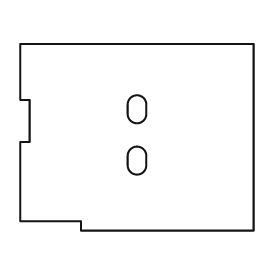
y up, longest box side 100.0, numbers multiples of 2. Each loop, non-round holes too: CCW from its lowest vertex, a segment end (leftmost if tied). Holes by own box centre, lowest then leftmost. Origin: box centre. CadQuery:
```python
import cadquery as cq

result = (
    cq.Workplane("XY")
    .moveTo(-24.0, -40.0)
    .lineTo(50.0, -40.0)
    .lineTo(50.0, 40.0)
    .lineTo(-50.0, 40.0)
    .lineTo(-50.0, 16.0)
    .lineTo(-46.0, 16.0)
    .lineTo(-46.0, -2.0)
    .lineTo(-50.0, -2.0)
    .lineTo(-50.0, -36.0)
    .lineTo(-24.0, -36.0)
    .close()
    .moveTo(-4.0, -12.0)
    .threePointArc((0.0, -16.0), (4.0, -12.0))
    .lineTo(4.0, -8.0)
    .threePointArc((0.0, -4.0), (-4.0, -8.0))
    .close()
    .moveTo(-4.0, 10.0)
    .threePointArc((0.0, 6.0), (4.0, 10.0))
    .lineTo(4.0, 14.0)
    .threePointArc((0.0, 18.0), (-4.0, 14.0))
    .close()
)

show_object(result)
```